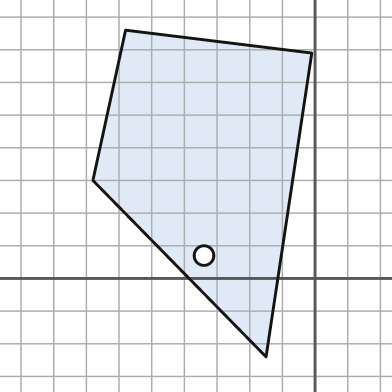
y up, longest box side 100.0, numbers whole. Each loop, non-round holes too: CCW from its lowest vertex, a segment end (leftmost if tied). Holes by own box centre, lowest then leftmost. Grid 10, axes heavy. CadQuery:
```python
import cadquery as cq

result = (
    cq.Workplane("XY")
    .moveTo(-15.0, -24.0)
    .lineTo(-1.0, 69.0)
    .lineTo(-58.0, 76.0)
    .lineTo(-68.0, 30.0)
    .close()
    .moveTo(-34.0, 7.0)
    .circle(3.0)
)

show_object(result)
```